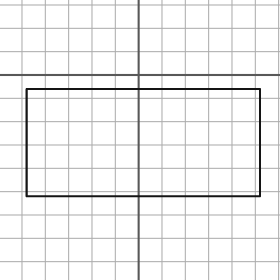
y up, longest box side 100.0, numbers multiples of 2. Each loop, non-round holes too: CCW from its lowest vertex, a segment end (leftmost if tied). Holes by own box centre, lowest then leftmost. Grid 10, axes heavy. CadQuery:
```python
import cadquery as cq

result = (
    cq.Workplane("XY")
    .moveTo(-48.0, -52.0)
    .lineTo(52.0, -52.0)
    .lineTo(52.0, -6.0)
    .lineTo(-48.0, -6.0)
    .close()
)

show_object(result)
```